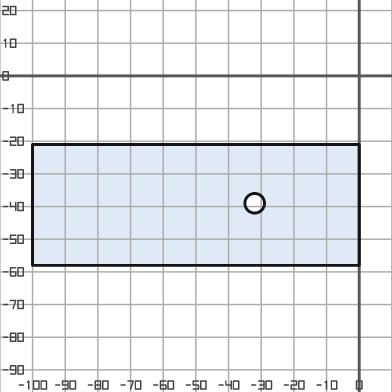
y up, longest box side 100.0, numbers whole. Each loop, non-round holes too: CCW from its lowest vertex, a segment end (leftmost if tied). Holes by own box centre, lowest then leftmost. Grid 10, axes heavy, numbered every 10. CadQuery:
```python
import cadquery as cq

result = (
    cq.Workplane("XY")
    .moveTo(-100.0, -58.0)
    .lineTo(0.0, -58.0)
    .lineTo(0.0, -21.0)
    .lineTo(-100.0, -21.0)
    .close()
    .moveTo(-32.0, -39.0)
    .circle(3.0)
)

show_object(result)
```